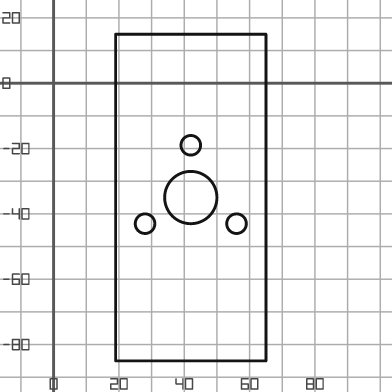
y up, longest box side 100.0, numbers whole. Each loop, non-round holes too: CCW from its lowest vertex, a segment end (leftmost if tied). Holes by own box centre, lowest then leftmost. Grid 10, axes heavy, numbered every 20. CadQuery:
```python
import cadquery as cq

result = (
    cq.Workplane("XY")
    .moveTo(19.0, -85.0)
    .lineTo(65.0, -85.0)
    .lineTo(65.0, 15.0)
    .lineTo(19.0, 15.0)
    .close()
    .moveTo(28.0, -43.0)
    .circle(3.0)
    .moveTo(56.0, -43.0)
    .circle(3.0)
    .moveTo(42.0, -35.0)
    .circle(8.0)
    .moveTo(42.0, -19.0)
    .circle(3.0)
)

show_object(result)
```